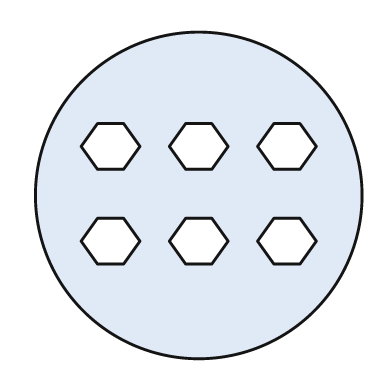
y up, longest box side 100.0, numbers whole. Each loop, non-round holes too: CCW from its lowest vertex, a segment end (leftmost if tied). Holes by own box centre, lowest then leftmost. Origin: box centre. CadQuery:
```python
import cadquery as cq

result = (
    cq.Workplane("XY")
    .moveTo(0.0, 0.0)
    .circle(50.0)
    .moveTo(-31.0, -21.0)
    .lineTo(-23.0, -21.0)
    .lineTo(-18.0, -14.0)
    .lineTo(-23.0, -7.0)
    .lineTo(-31.0, -7.0)
    .lineTo(-36.0, -14.0)
    .close()
    .moveTo(-4.0, -21.0)
    .lineTo(4.0, -21.0)
    .lineTo(9.0, -14.0)
    .lineTo(4.0, -7.0)
    .lineTo(-4.0, -7.0)
    .lineTo(-9.0, -14.0)
    .close()
    .moveTo(23.0, -21.0)
    .lineTo(31.0, -21.0)
    .lineTo(36.0, -14.0)
    .lineTo(31.0, -7.0)
    .lineTo(23.0, -7.0)
    .lineTo(18.0, -14.0)
    .close()
    .moveTo(-31.0, 8.0)
    .lineTo(-23.0, 8.0)
    .lineTo(-18.0, 15.0)
    .lineTo(-23.0, 22.0)
    .lineTo(-31.0, 22.0)
    .lineTo(-36.0, 15.0)
    .close()
    .moveTo(-4.0, 8.0)
    .lineTo(4.0, 8.0)
    .lineTo(9.0, 15.0)
    .lineTo(4.0, 22.0)
    .lineTo(-4.0, 22.0)
    .lineTo(-9.0, 15.0)
    .close()
    .moveTo(23.0, 8.0)
    .lineTo(31.0, 8.0)
    .lineTo(36.0, 15.0)
    .lineTo(31.0, 22.0)
    .lineTo(23.0, 22.0)
    .lineTo(18.0, 15.0)
    .close()
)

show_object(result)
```